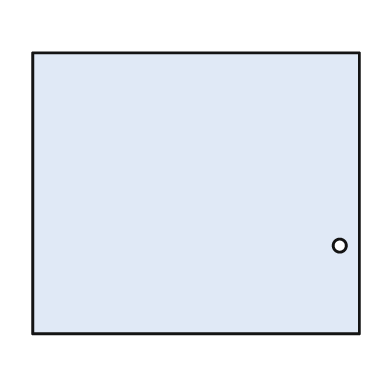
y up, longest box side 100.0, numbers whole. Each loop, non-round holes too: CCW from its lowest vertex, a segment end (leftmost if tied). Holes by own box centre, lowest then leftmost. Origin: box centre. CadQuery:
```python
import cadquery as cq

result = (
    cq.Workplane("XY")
    .moveTo(-50.0, -43.0)
    .lineTo(50.0, -43.0)
    .lineTo(50.0, 43.0)
    .lineTo(-50.0, 43.0)
    .close()
    .moveTo(44.0, -16.0)
    .circle(2.0)
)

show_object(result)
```